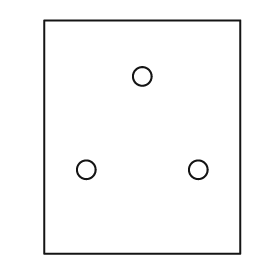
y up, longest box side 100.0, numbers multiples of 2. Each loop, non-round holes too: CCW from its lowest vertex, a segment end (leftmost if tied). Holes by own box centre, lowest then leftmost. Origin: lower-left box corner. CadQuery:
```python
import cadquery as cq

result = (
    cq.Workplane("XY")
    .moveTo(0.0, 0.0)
    .lineTo(84.0, 0.0)
    .lineTo(84.0, 100.0)
    .lineTo(0.0, 100.0)
    .close()
    .moveTo(18.0, 36.0)
    .circle(4.0)
    .moveTo(66.0, 36.0)
    .circle(4.0)
    .moveTo(42.0, 76.0)
    .circle(4.0)
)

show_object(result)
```